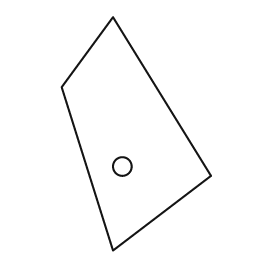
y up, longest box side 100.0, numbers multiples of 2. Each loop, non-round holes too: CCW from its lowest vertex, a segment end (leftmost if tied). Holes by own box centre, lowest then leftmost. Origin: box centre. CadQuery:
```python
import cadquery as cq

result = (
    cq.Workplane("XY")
    .moveTo(-10.0, -50.0)
    .lineTo(32.0, -18.0)
    .lineTo(-10.0, 50.0)
    .lineTo(-32.0, 20.0)
    .close()
    .moveTo(-6.0, -14.0)
    .circle(4.0)
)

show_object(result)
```